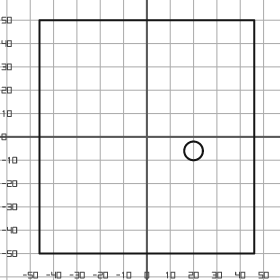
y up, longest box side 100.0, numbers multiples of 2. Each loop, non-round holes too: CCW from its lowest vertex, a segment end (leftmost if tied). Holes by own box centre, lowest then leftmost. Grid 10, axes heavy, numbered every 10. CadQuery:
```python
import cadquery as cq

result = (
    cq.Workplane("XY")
    .moveTo(-46.0, -50.0)
    .lineTo(46.0, -50.0)
    .lineTo(46.0, 50.0)
    .lineTo(-46.0, 50.0)
    .close()
    .moveTo(20.0, -6.0)
    .circle(4.0)
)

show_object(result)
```